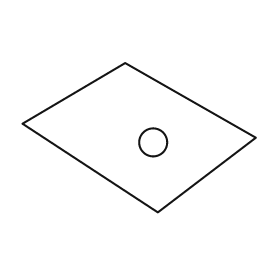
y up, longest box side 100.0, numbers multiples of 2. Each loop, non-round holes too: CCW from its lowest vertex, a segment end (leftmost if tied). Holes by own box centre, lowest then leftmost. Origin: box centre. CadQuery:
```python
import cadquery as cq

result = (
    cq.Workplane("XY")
    .moveTo(8.0, -32.0)
    .lineTo(50.0, 0.0)
    .lineTo(-6.0, 32.0)
    .lineTo(-50.0, 6.0)
    .close()
    .moveTo(6.0, -2.0)
    .circle(6.0)
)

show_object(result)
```